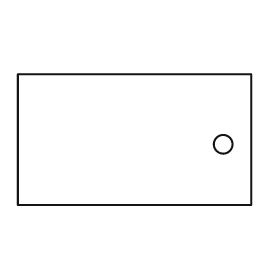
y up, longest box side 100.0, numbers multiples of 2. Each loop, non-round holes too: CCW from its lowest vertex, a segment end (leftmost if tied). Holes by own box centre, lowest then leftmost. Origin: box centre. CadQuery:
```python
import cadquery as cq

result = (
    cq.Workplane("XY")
    .moveTo(-50.0, -28.0)
    .lineTo(50.0, -28.0)
    .lineTo(50.0, 28.0)
    .lineTo(-50.0, 28.0)
    .close()
    .moveTo(38.0, -2.0)
    .circle(4.0)
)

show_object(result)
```